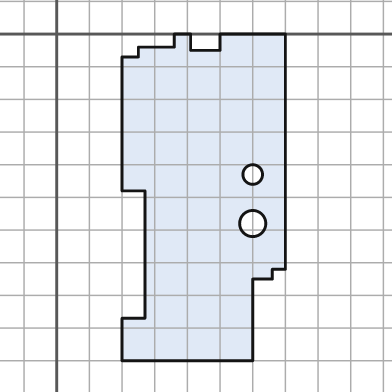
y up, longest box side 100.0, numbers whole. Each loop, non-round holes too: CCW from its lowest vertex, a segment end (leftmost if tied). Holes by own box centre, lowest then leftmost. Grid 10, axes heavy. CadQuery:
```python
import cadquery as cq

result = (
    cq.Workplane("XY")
    .moveTo(20.0, -100.0)
    .lineTo(60.0, -100.0)
    .lineTo(60.0, -75.0)
    .lineTo(66.0, -75.0)
    .lineTo(66.0, -72.0)
    .lineTo(70.0, -72.0)
    .lineTo(70.0, 0.0)
    .lineTo(50.0, 0.0)
    .lineTo(50.0, -5.0)
    .lineTo(41.0, -5.0)
    .lineTo(41.0, 0.0)
    .lineTo(36.0, 0.0)
    .lineTo(36.0, -4.0)
    .lineTo(25.0, -4.0)
    .lineTo(25.0, -7.0)
    .lineTo(20.0, -7.0)
    .lineTo(20.0, -48.0)
    .lineTo(27.0, -48.0)
    .lineTo(27.0, -87.0)
    .lineTo(20.0, -87.0)
    .close()
    .moveTo(60.0, -58.0)
    .circle(4.0)
    .moveTo(60.0, -43.0)
    .circle(3.0)
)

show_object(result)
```